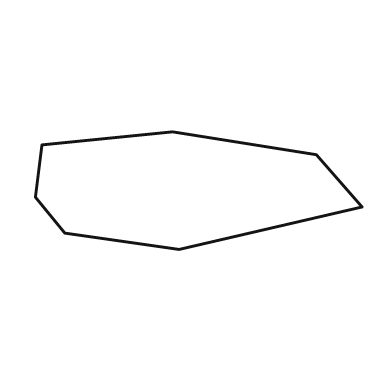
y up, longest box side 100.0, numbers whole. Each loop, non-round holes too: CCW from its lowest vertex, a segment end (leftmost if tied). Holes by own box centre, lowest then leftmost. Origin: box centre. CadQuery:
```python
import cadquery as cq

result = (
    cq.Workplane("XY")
    .moveTo(-6.0, -18.0)
    .lineTo(50.0, -5.0)
    .lineTo(36.0, 11.0)
    .lineTo(-8.0, 18.0)
    .lineTo(-48.0, 14.0)
    .lineTo(-50.0, -2.0)
    .lineTo(-41.0, -13.0)
    .close()
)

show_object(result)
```